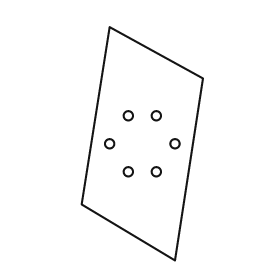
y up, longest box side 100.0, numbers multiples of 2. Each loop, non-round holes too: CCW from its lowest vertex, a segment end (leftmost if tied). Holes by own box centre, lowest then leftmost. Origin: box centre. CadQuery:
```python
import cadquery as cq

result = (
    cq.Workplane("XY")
    .moveTo(14.0, -50.0)
    .lineTo(26.0, 28.0)
    .lineTo(-14.0, 50.0)
    .lineTo(-26.0, -26.0)
    .close()
    .moveTo(-6.0, -12.0)
    .circle(2.0)
    .moveTo(6.0, -12.0)
    .circle(2.0)
    .moveTo(-14.0, 0.0)
    .circle(2.0)
    .moveTo(14.0, 0.0)
    .circle(2.0)
    .moveTo(-6.0, 12.0)
    .circle(2.0)
    .moveTo(6.0, 12.0)
    .circle(2.0)
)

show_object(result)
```